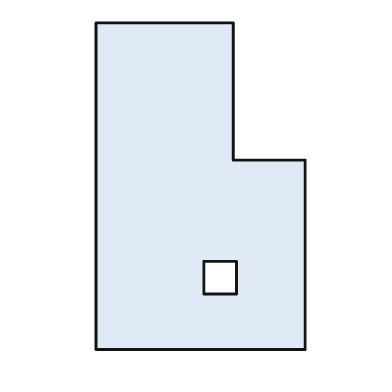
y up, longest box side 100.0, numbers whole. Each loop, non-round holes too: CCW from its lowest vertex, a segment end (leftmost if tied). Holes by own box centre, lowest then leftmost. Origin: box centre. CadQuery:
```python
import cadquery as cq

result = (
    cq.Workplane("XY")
    .moveTo(-32.0, -50.0)
    .lineTo(32.0, -50.0)
    .lineTo(32.0, 8.0)
    .lineTo(10.0, 8.0)
    .lineTo(10.0, 50.0)
    .lineTo(-32.0, 50.0)
    .close()
    .moveTo(1.0, -33.0)
    .lineTo(11.0, -33.0)
    .lineTo(11.0, -23.0)
    .lineTo(1.0, -23.0)
    .close()
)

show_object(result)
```